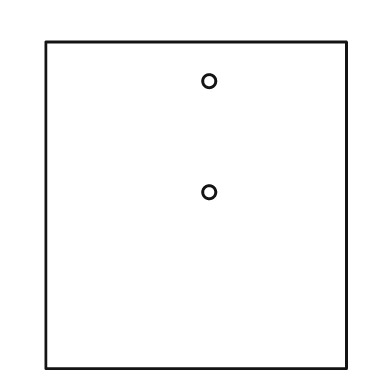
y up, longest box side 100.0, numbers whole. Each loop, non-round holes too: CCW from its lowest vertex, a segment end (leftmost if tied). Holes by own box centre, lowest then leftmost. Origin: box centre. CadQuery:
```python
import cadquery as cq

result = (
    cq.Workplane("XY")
    .moveTo(-46.0, -50.0)
    .lineTo(46.0, -50.0)
    .lineTo(46.0, 50.0)
    .lineTo(-46.0, 50.0)
    .close()
    .moveTo(4.0, 4.0)
    .circle(2.0)
    .moveTo(4.0, 38.0)
    .circle(2.0)
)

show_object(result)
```